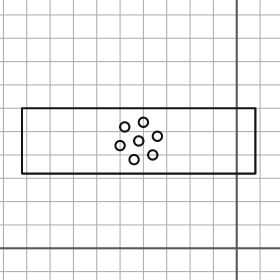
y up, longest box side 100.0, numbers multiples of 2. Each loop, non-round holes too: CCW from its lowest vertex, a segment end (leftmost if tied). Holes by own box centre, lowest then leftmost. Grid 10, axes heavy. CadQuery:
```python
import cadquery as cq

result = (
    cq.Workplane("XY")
    .moveTo(-92.0, 32.0)
    .lineTo(8.0, 32.0)
    .lineTo(8.0, 60.0)
    .lineTo(-92.0, 60.0)
    .close()
    .moveTo(-44.0, 38.0)
    .circle(2.0)
    .moveTo(-36.0, 40.0)
    .circle(2.0)
    .moveTo(-50.0, 44.0)
    .circle(2.0)
    .moveTo(-42.0, 46.0)
    .circle(2.0)
    .moveTo(-34.0, 48.0)
    .circle(2.0)
    .moveTo(-48.0, 52.0)
    .circle(2.0)
    .moveTo(-40.0, 54.0)
    .circle(2.0)
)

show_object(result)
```